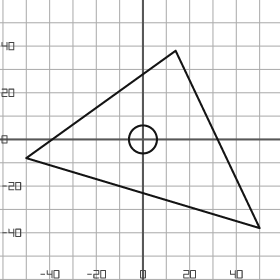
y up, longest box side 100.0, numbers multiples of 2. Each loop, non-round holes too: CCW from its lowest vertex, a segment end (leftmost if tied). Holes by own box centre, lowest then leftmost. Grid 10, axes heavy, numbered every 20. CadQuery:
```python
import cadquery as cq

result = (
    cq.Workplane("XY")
    .moveTo(50.0, -38.0)
    .lineTo(14.0, 38.0)
    .lineTo(-50.0, -8.0)
    .close()
    .moveTo(0.0, 0.0)
    .circle(6.0)
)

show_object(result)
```